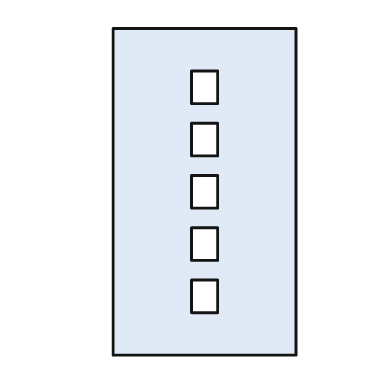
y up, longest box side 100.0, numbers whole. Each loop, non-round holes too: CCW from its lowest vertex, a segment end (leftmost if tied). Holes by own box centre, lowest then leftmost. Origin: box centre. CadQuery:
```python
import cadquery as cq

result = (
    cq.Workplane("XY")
    .moveTo(-28.0, -50.0)
    .lineTo(28.0, -50.0)
    .lineTo(28.0, 50.0)
    .lineTo(-28.0, 50.0)
    .close()
    .moveTo(-4.0, -37.0)
    .lineTo(4.0, -37.0)
    .lineTo(4.0, -27.0)
    .lineTo(-4.0, -27.0)
    .close()
    .moveTo(-4.0, -21.0)
    .lineTo(4.0, -21.0)
    .lineTo(4.0, -11.0)
    .lineTo(-4.0, -11.0)
    .close()
    .moveTo(-4.0, -5.0)
    .lineTo(4.0, -5.0)
    .lineTo(4.0, 5.0)
    .lineTo(-4.0, 5.0)
    .close()
    .moveTo(-4.0, 11.0)
    .lineTo(4.0, 11.0)
    .lineTo(4.0, 21.0)
    .lineTo(-4.0, 21.0)
    .close()
    .moveTo(-4.0, 27.0)
    .lineTo(4.0, 27.0)
    .lineTo(4.0, 37.0)
    .lineTo(-4.0, 37.0)
    .close()
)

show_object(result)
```